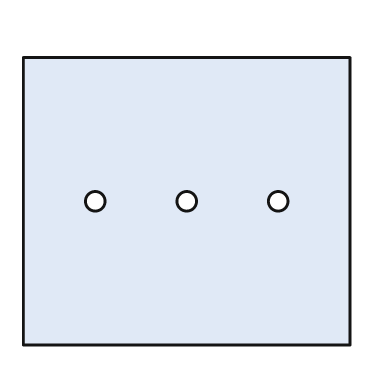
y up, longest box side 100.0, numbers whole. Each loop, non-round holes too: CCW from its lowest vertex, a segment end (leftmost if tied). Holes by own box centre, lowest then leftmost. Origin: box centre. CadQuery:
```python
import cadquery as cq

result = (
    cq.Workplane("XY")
    .moveTo(-50.0, -44.0)
    .lineTo(50.0, -44.0)
    .lineTo(50.0, 44.0)
    .lineTo(-50.0, 44.0)
    .close()
    .moveTo(-28.0, 0.0)
    .circle(3.0)
    .moveTo(0.0, 0.0)
    .circle(3.0)
    .moveTo(28.0, 0.0)
    .circle(3.0)
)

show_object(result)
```